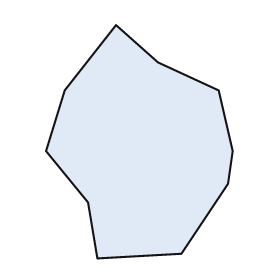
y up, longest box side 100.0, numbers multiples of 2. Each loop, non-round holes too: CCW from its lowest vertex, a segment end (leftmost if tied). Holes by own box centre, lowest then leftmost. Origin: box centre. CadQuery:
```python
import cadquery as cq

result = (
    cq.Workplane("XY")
    .moveTo(-18.0, -50.0)
    .lineTo(18.0, -48.0)
    .lineTo(38.0, -18.0)
    .lineTo(40.0, -4.0)
    .lineTo(34.0, 22.0)
    .lineTo(8.0, 34.0)
    .lineTo(-10.0, 50.0)
    .lineTo(-32.0, 22.0)
    .lineTo(-40.0, -4.0)
    .lineTo(-22.0, -26.0)
    .close()
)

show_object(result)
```